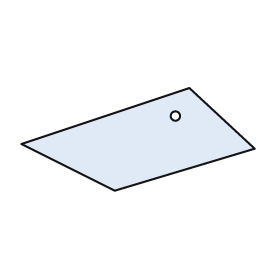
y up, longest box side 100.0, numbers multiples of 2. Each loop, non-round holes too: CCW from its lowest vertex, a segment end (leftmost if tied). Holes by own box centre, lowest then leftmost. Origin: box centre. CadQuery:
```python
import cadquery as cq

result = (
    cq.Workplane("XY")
    .moveTo(-10.0, -22.0)
    .lineTo(50.0, -4.0)
    .lineTo(22.0, 22.0)
    .lineTo(-50.0, -2.0)
    .close()
    .moveTo(16.0, 10.0)
    .circle(2.0)
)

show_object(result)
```